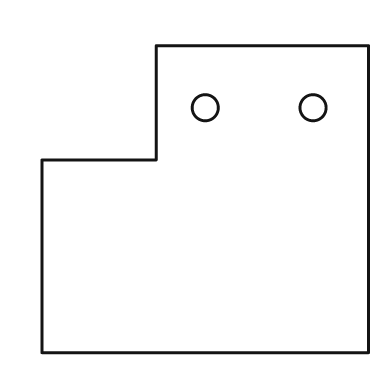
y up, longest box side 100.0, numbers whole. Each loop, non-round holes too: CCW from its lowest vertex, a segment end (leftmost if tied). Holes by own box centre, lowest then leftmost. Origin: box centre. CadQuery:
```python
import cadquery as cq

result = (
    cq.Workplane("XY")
    .moveTo(-50.0, -47.0)
    .lineTo(50.0, -47.0)
    .lineTo(50.0, 47.0)
    .lineTo(-15.0, 47.0)
    .lineTo(-15.0, 12.0)
    .lineTo(-50.0, 12.0)
    .close()
    .moveTo(0.0, 28.0)
    .circle(4.0)
    .moveTo(33.0, 28.0)
    .circle(4.0)
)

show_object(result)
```